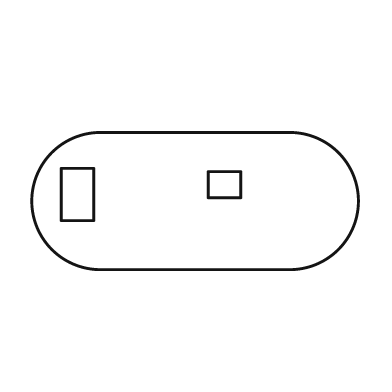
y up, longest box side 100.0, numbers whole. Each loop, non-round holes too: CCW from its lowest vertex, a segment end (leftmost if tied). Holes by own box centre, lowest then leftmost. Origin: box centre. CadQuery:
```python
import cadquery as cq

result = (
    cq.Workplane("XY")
    .moveTo(-29.0, -21.0)
    .lineTo(29.0, -21.0)
    .threePointArc((50.0, 0.0), (29.0, 21.0))
    .lineTo(-29.0, 21.0)
    .threePointArc((-50.0, 0.0), (-29.0, -21.0))
    .close()
    .moveTo(-41.0, -6.0)
    .lineTo(-31.0, -6.0)
    .lineTo(-31.0, 10.0)
    .lineTo(-41.0, 10.0)
    .close()
    .moveTo(4.0, 1.0)
    .lineTo(14.0, 1.0)
    .lineTo(14.0, 9.0)
    .lineTo(4.0, 9.0)
    .close()
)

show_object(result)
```